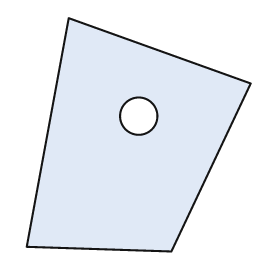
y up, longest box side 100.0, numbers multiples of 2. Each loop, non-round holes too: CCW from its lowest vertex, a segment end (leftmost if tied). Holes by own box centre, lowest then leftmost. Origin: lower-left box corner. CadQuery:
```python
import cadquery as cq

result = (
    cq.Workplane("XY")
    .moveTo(62.0, 0.0)
    .lineTo(96.0, 72.0)
    .lineTo(18.0, 100.0)
    .lineTo(0.0, 2.0)
    .close()
    .moveTo(48.0, 58.0)
    .circle(8.0)
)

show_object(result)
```